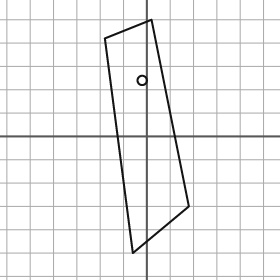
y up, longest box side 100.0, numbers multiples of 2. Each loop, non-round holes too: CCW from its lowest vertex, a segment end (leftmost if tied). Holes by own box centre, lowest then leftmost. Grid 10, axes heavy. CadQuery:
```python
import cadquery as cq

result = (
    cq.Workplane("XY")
    .moveTo(-6.0, -50.0)
    .lineTo(18.0, -30.0)
    .lineTo(2.0, 50.0)
    .lineTo(-18.0, 42.0)
    .close()
    .moveTo(-2.0, 24.0)
    .circle(2.0)
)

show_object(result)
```